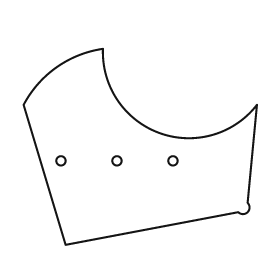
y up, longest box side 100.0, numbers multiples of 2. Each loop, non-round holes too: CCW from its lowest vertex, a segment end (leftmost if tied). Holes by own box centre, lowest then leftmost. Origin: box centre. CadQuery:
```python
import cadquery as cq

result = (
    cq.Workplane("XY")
    .moveTo(-32.0, -42.0)
    .lineTo(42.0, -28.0)
    .threePointArc((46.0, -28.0), (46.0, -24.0))
    .lineTo(50.0, 18.0)
    .threePointArc((8.0, 6.0), (-16.0, 42.0))
    .threePointArc((-36.0, 34.0), (-50.0, 18.0))
    .close()
    .moveTo(-34.0, -6.0)
    .circle(2.0)
    .moveTo(-10.0, -6.0)
    .circle(2.0)
    .moveTo(14.0, -6.0)
    .circle(2.0)
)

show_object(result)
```